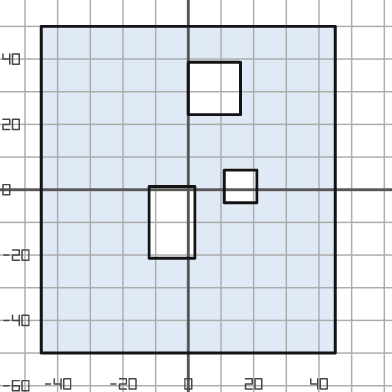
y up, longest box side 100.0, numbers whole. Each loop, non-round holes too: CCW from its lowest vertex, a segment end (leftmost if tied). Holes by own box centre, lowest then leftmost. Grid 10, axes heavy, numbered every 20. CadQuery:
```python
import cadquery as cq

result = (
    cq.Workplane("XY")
    .moveTo(-45.0, -50.0)
    .lineTo(45.0, -50.0)
    .lineTo(45.0, 50.0)
    .lineTo(-45.0, 50.0)
    .close()
    .moveTo(-12.0, -21.0)
    .lineTo(2.0, -21.0)
    .lineTo(2.0, 1.0)
    .lineTo(-12.0, 1.0)
    .close()
    .moveTo(11.0, -4.0)
    .lineTo(21.0, -4.0)
    .lineTo(21.0, 6.0)
    .lineTo(11.0, 6.0)
    .close()
    .moveTo(0.0, 23.0)
    .lineTo(16.0, 23.0)
    .lineTo(16.0, 39.0)
    .lineTo(0.0, 39.0)
    .close()
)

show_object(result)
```